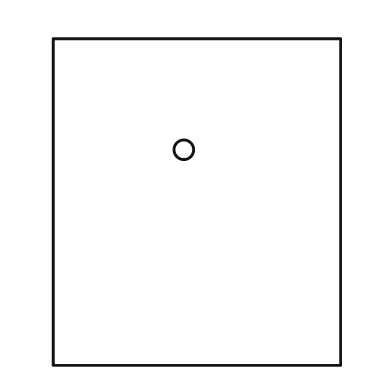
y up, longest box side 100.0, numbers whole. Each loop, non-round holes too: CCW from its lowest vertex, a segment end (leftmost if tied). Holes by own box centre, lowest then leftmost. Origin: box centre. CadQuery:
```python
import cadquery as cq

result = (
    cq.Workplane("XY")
    .moveTo(-44.0, -50.0)
    .lineTo(44.0, -50.0)
    .lineTo(44.0, 50.0)
    .lineTo(-44.0, 50.0)
    .close()
    .moveTo(-4.0, 16.0)
    .circle(3.0)
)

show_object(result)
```